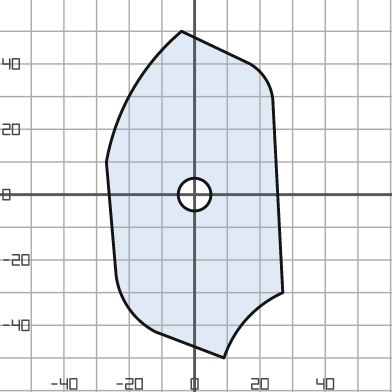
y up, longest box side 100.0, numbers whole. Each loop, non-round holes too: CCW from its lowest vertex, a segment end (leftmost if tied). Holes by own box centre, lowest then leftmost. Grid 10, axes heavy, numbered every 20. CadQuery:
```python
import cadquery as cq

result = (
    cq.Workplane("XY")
    .moveTo(9.0, -50.0)
    .threePointArc((16.0, -38.0), (27.0, -30.0))
    .lineTo(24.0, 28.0)
    .threePointArc((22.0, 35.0), (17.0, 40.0))
    .lineTo(-4.0, 50.0)
    .threePointArc((-19.0, 32.0), (-27.0, 10.0))
    .lineTo(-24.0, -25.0)
    .threePointArc((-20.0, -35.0), (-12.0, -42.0))
    .close()
    .moveTo(0.0, 0.0)
    .circle(5.0)
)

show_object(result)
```